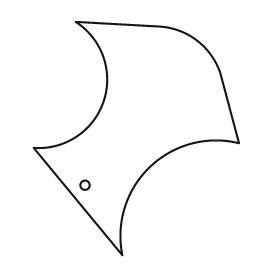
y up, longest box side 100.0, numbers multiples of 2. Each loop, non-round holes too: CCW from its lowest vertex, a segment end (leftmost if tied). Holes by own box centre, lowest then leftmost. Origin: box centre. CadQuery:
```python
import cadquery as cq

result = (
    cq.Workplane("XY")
    .moveTo(-6.0, -50.0)
    .threePointArc((6.0, -12.0), (44.0, -2.0))
    .lineTo(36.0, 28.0)
    .threePointArc((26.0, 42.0), (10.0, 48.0))
    .lineTo(-26.0, 50.0)
    .threePointArc((-14.0, 16.0), (-44.0, -4.0))
    .close()
    .moveTo(-22.0, -20.0)
    .circle(2.0)
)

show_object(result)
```